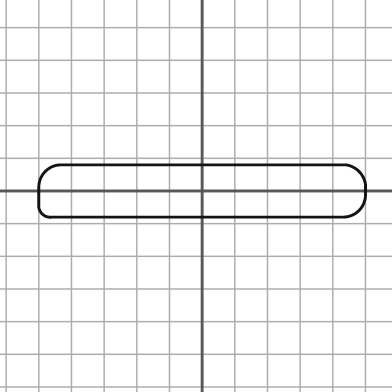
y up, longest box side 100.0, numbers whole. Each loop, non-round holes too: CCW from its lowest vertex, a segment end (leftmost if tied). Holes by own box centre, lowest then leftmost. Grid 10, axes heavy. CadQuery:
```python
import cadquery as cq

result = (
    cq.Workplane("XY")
    .moveTo(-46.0, -8.0)
    .lineTo(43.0, -8.0)
    .threePointArc((48.0, -6.0), (50.0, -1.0))
    .lineTo(50.0, 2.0)
    .threePointArc((48.0, 6.0), (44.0, 8.0))
    .lineTo(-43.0, 8.0)
    .threePointArc((-48.0, 6.0), (-50.0, 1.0))
    .lineTo(-50.0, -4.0)
    .threePointArc((-49.0, -7.0), (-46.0, -8.0))
    .close()
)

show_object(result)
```